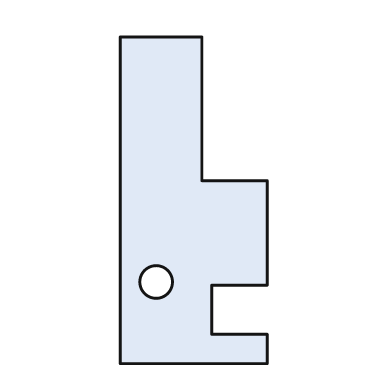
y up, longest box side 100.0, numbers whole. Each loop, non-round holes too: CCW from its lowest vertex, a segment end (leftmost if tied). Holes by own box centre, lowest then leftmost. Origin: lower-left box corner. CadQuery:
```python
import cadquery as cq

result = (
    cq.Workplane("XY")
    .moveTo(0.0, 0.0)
    .lineTo(45.0, 0.0)
    .lineTo(45.0, 9.0)
    .lineTo(28.0, 9.0)
    .lineTo(28.0, 24.0)
    .lineTo(45.0, 24.0)
    .lineTo(45.0, 56.0)
    .lineTo(25.0, 56.0)
    .lineTo(25.0, 100.0)
    .lineTo(0.0, 100.0)
    .close()
    .moveTo(11.0, 25.0)
    .circle(5.0)
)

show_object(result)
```